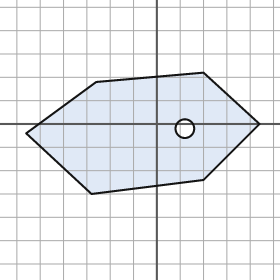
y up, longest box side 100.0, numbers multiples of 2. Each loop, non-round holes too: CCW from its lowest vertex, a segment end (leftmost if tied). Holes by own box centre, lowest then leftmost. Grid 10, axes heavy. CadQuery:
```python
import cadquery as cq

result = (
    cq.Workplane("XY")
    .moveTo(-28.0, -30.0)
    .lineTo(20.0, -24.0)
    .lineTo(44.0, 0.0)
    .lineTo(20.0, 22.0)
    .lineTo(-26.0, 18.0)
    .lineTo(-56.0, -4.0)
    .close()
    .moveTo(12.0, -2.0)
    .circle(4.0)
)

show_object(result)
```